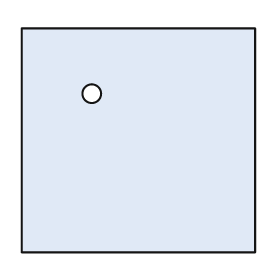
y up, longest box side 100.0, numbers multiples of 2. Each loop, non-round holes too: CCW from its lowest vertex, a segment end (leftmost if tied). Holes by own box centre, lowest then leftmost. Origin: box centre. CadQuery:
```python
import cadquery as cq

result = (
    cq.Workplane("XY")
    .moveTo(-50.0, -48.0)
    .lineTo(50.0, -48.0)
    .lineTo(50.0, 48.0)
    .lineTo(-50.0, 48.0)
    .close()
    .moveTo(-20.0, 20.0)
    .circle(4.0)
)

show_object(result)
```